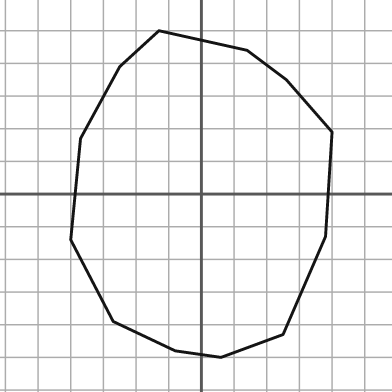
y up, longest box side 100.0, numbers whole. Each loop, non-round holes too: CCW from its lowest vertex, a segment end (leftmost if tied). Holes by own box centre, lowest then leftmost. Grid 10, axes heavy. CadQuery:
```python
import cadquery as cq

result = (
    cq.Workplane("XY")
    .moveTo(6.0, -50.0)
    .lineTo(25.0, -43.0)
    .lineTo(38.0, -13.0)
    .lineTo(40.0, 19.0)
    .lineTo(26.0, 35.0)
    .lineTo(14.0, 44.0)
    .lineTo(-13.0, 50.0)
    .lineTo(-25.0, 39.0)
    .lineTo(-37.0, 17.0)
    .lineTo(-40.0, -14.0)
    .lineTo(-27.0, -39.0)
    .lineTo(-8.0, -48.0)
    .close()
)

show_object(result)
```